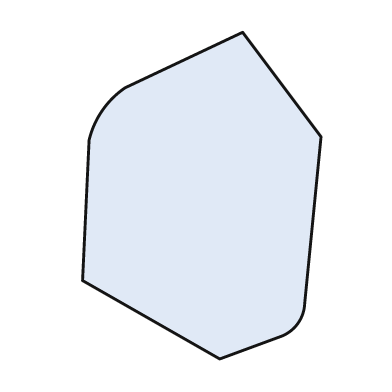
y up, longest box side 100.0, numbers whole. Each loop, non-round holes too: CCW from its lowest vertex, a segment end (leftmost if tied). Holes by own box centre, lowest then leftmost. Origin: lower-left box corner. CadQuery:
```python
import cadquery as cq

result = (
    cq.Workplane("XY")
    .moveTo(42.0, 0.0)
    .lineTo(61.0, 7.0)
    .threePointArc((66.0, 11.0), (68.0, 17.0))
    .lineTo(73.0, 68.0)
    .lineTo(49.0, 100.0)
    .lineTo(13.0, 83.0)
    .threePointArc((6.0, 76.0), (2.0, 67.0))
    .lineTo(0.0, 24.0)
    .close()
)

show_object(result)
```